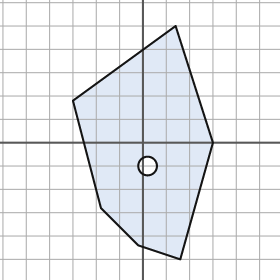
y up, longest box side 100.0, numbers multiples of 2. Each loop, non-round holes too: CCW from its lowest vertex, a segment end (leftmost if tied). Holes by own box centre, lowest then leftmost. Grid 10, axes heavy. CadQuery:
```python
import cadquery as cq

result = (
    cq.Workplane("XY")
    .moveTo(16.0, -50.0)
    .lineTo(30.0, 0.0)
    .lineTo(14.0, 50.0)
    .lineTo(-30.0, 18.0)
    .lineTo(-18.0, -28.0)
    .lineTo(-2.0, -44.0)
    .close()
    .moveTo(2.0, -10.0)
    .circle(4.0)
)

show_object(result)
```